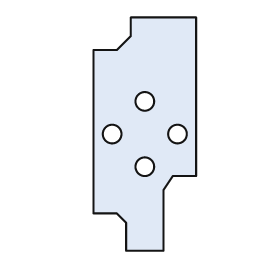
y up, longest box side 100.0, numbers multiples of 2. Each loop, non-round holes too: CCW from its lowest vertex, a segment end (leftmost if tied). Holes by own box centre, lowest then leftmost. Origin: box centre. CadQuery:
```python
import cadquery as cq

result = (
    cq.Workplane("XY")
    .moveTo(-8.0, -50.0)
    .lineTo(8.0, -50.0)
    .lineTo(8.0, -24.0)
    .lineTo(12.0, -18.0)
    .lineTo(22.0, -18.0)
    .lineTo(22.0, 50.0)
    .lineTo(-6.0, 50.0)
    .lineTo(-6.0, 42.0)
    .lineTo(-12.0, 36.0)
    .lineTo(-22.0, 36.0)
    .lineTo(-22.0, -34.0)
    .lineTo(-12.0, -34.0)
    .lineTo(-8.0, -38.0)
    .close()
    .moveTo(0.0, -14.0)
    .circle(4.0)
    .moveTo(-14.0, 0.0)
    .circle(4.0)
    .moveTo(14.0, 0.0)
    .circle(4.0)
    .moveTo(0.0, 14.0)
    .circle(4.0)
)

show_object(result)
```